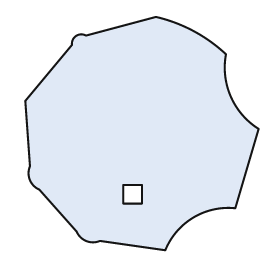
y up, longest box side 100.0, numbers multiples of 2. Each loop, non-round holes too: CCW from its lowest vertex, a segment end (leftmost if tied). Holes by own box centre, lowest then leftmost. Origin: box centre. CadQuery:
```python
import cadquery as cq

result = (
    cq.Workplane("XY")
    .moveTo(10.0, -50.0)
    .threePointArc((22.0, -36.0), (40.0, -32.0))
    .lineTo(50.0, 2.0)
    .threePointArc((38.0, 16.0), (36.0, 34.0))
    .threePointArc((22.0, 44.0), (6.0, 50.0))
    .lineTo(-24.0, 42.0)
    .threePointArc((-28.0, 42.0), (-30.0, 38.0))
    .lineTo(-50.0, 14.0)
    .lineTo(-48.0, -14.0)
    .threePointArc((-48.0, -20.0), (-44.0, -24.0))
    .lineTo(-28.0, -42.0)
    .threePointArc((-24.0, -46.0), (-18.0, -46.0))
    .close()
    .moveTo(-8.0, -30.0)
    .lineTo(0.0, -30.0)
    .lineTo(0.0, -22.0)
    .lineTo(-8.0, -22.0)
    .close()
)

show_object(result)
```